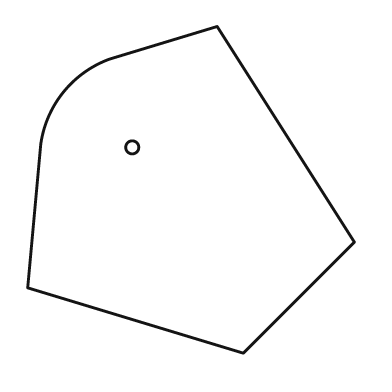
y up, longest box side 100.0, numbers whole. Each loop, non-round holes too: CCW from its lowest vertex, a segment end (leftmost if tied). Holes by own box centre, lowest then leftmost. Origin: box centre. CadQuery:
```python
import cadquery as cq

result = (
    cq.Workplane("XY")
    .moveTo(16.0, -50.0)
    .lineTo(50.0, -16.0)
    .lineTo(8.0, 50.0)
    .lineTo(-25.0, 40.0)
    .threePointArc((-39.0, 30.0), (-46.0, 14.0))
    .lineTo(-50.0, -30.0)
    .close()
    .moveTo(-18.0, 13.0)
    .circle(2.0)
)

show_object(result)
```